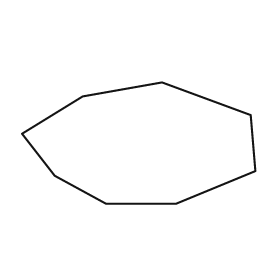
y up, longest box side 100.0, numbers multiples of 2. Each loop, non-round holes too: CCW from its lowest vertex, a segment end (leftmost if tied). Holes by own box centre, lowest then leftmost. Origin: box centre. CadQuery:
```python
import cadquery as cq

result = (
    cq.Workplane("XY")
    .moveTo(-14.0, -26.0)
    .lineTo(16.0, -26.0)
    .lineTo(50.0, -12.0)
    .lineTo(48.0, 12.0)
    .lineTo(10.0, 26.0)
    .lineTo(-24.0, 20.0)
    .lineTo(-50.0, 4.0)
    .lineTo(-36.0, -14.0)
    .close()
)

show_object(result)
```